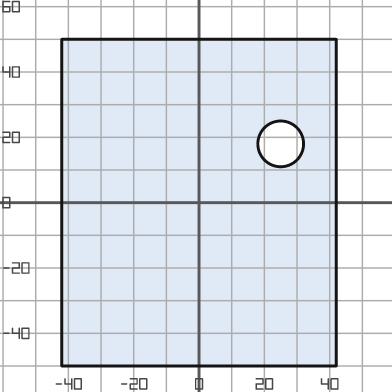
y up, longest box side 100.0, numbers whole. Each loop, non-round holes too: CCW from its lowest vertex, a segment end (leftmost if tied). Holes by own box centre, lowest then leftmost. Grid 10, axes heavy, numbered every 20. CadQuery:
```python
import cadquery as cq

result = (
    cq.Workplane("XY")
    .moveTo(-42.0, -50.0)
    .lineTo(42.0, -50.0)
    .lineTo(42.0, 50.0)
    .lineTo(-42.0, 50.0)
    .close()
    .moveTo(25.0, 18.0)
    .circle(7.0)
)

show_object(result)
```